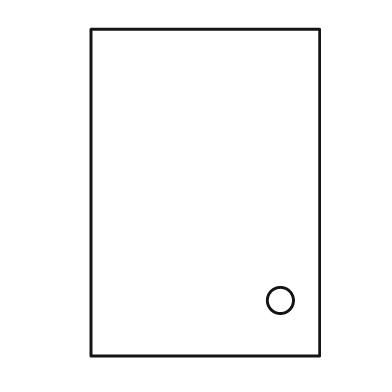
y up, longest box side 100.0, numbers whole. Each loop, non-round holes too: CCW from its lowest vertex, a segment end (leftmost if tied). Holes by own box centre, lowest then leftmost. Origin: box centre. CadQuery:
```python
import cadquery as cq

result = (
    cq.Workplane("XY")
    .moveTo(-35.0, -50.0)
    .lineTo(35.0, -50.0)
    .lineTo(35.0, 50.0)
    .lineTo(-35.0, 50.0)
    .close()
    .moveTo(23.0, -33.0)
    .circle(4.0)
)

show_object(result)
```